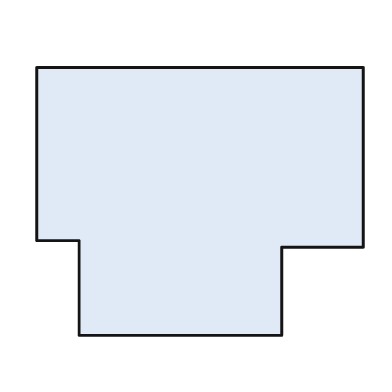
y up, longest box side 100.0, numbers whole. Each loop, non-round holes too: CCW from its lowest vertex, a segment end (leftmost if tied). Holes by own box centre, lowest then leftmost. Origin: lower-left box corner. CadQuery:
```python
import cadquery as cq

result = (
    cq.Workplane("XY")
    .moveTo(13.0, 0.0)
    .lineTo(75.0, 0.0)
    .lineTo(75.0, 27.0)
    .lineTo(100.0, 27.0)
    .lineTo(100.0, 82.0)
    .lineTo(0.0, 82.0)
    .lineTo(0.0, 29.0)
    .lineTo(13.0, 29.0)
    .close()
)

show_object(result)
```